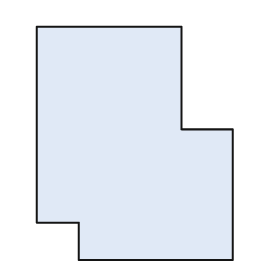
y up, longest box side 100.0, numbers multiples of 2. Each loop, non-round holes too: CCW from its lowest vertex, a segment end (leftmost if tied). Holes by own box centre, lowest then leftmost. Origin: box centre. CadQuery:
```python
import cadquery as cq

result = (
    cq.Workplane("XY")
    .moveTo(-24.0, -50.0)
    .lineTo(42.0, -50.0)
    .lineTo(42.0, 6.0)
    .lineTo(20.0, 6.0)
    .lineTo(20.0, 50.0)
    .lineTo(-42.0, 50.0)
    .lineTo(-42.0, -34.0)
    .lineTo(-24.0, -34.0)
    .close()
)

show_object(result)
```